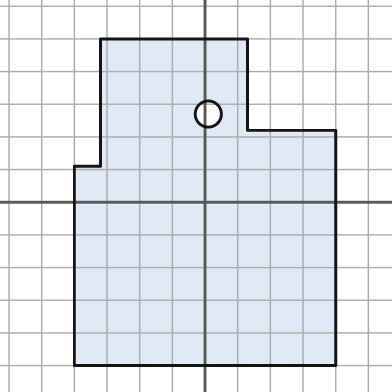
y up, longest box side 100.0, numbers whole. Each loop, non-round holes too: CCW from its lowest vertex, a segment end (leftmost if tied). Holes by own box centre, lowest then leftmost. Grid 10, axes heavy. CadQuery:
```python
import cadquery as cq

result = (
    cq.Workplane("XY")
    .moveTo(-40.0, -50.0)
    .lineTo(40.0, -50.0)
    .lineTo(40.0, 22.0)
    .lineTo(13.0, 22.0)
    .lineTo(13.0, 50.0)
    .lineTo(-32.0, 50.0)
    .lineTo(-32.0, 11.0)
    .lineTo(-40.0, 11.0)
    .close()
    .moveTo(1.0, 27.0)
    .circle(4.0)
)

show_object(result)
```